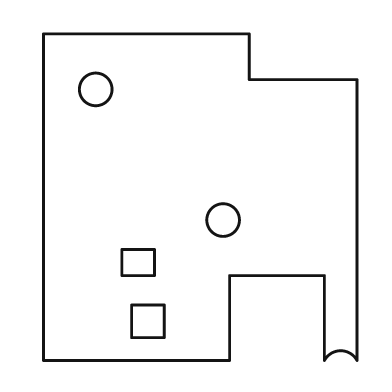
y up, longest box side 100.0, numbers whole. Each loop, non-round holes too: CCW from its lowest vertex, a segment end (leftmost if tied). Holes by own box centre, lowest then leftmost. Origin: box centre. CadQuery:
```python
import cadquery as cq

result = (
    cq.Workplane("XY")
    .moveTo(-48.0, -50.0)
    .lineTo(9.0, -50.0)
    .lineTo(9.0, -24.0)
    .lineTo(38.0, -24.0)
    .lineTo(38.0, -50.0)
    .threePointArc((43.0, -47.0), (48.0, -50.0))
    .lineTo(48.0, 36.0)
    .lineTo(15.0, 36.0)
    .lineTo(15.0, 50.0)
    .lineTo(-48.0, 50.0)
    .close()
    .moveTo(-21.0, -43.0)
    .lineTo(-11.0, -43.0)
    .lineTo(-11.0, -33.0)
    .lineTo(-21.0, -33.0)
    .close()
    .moveTo(-24.0, -24.0)
    .lineTo(-14.0, -24.0)
    .lineTo(-14.0, -16.0)
    .lineTo(-24.0, -16.0)
    .close()
    .moveTo(7.0, -7.0)
    .circle(5.0)
    .moveTo(-32.0, 33.0)
    .circle(5.0)
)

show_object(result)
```